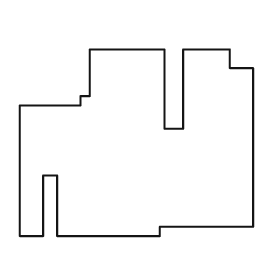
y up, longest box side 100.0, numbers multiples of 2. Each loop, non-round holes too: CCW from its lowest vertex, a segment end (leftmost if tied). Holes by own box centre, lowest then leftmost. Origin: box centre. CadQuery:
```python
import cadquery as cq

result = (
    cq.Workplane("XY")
    .moveTo(-50.0, -40.0)
    .lineTo(-40.0, -40.0)
    .lineTo(-40.0, -14.0)
    .lineTo(-34.0, -14.0)
    .lineTo(-34.0, -40.0)
    .lineTo(10.0, -40.0)
    .lineTo(10.0, -36.0)
    .lineTo(50.0, -36.0)
    .lineTo(50.0, 32.0)
    .lineTo(40.0, 32.0)
    .lineTo(40.0, 40.0)
    .lineTo(20.0, 40.0)
    .lineTo(20.0, 6.0)
    .lineTo(12.0, 6.0)
    .lineTo(12.0, 40.0)
    .lineTo(-20.0, 40.0)
    .lineTo(-20.0, 20.0)
    .lineTo(-24.0, 20.0)
    .lineTo(-24.0, 16.0)
    .lineTo(-50.0, 16.0)
    .close()
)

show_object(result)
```